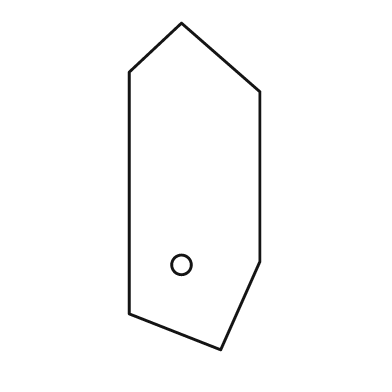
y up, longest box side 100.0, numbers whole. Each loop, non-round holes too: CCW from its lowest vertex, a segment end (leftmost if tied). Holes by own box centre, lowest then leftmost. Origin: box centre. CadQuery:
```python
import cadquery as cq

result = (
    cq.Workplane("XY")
    .moveTo(8.0, -50.0)
    .lineTo(20.0, -23.0)
    .lineTo(20.0, 29.0)
    .lineTo(-4.0, 50.0)
    .lineTo(-20.0, 35.0)
    .lineTo(-20.0, -39.0)
    .close()
    .moveTo(-4.0, -24.0)
    .circle(3.0)
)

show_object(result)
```